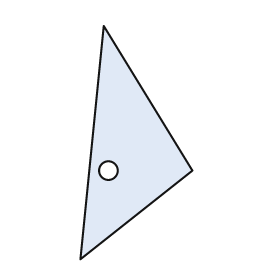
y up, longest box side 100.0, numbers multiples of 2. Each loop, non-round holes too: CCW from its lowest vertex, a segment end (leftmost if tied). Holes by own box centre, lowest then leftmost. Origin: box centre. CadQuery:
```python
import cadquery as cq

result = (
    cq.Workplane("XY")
    .moveTo(-24.0, -50.0)
    .lineTo(24.0, -12.0)
    .lineTo(-14.0, 50.0)
    .close()
    .moveTo(-12.0, -12.0)
    .circle(4.0)
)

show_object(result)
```